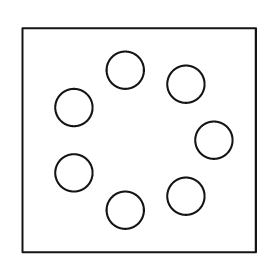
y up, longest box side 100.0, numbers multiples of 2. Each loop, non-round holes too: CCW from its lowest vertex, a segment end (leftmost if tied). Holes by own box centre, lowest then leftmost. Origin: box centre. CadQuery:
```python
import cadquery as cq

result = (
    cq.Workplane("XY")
    .moveTo(-50.0, -48.0)
    .lineTo(50.0, -48.0)
    .lineTo(50.0, 48.0)
    .lineTo(-50.0, 48.0)
    .close()
    .moveTo(-6.0, -30.0)
    .circle(8.0)
    .moveTo(20.0, -24.0)
    .circle(8.0)
    .moveTo(-28.0, -14.0)
    .circle(8.0)
    .moveTo(32.0, 0.0)
    .circle(8.0)
    .moveTo(-28.0, 14.0)
    .circle(8.0)
    .moveTo(20.0, 24.0)
    .circle(8.0)
    .moveTo(-6.0, 30.0)
    .circle(8.0)
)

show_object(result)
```